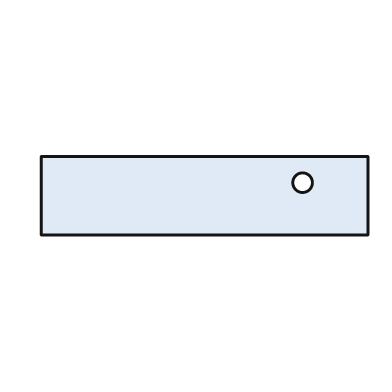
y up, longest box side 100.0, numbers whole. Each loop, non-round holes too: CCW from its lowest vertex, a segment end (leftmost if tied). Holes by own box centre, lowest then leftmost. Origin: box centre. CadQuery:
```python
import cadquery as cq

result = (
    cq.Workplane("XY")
    .moveTo(-50.0, -12.0)
    .lineTo(50.0, -12.0)
    .lineTo(50.0, 12.0)
    .lineTo(-50.0, 12.0)
    .close()
    .moveTo(30.0, 4.0)
    .circle(3.0)
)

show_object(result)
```